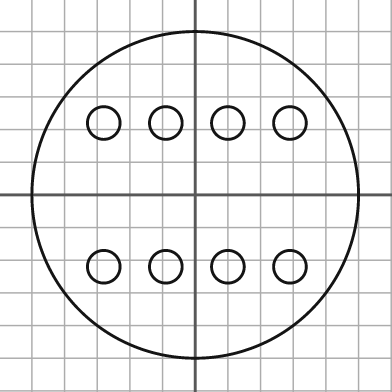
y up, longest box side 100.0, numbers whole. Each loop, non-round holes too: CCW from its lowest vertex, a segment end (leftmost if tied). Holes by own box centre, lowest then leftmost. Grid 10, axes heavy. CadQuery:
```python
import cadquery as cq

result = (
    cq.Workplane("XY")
    .moveTo(0.0, 0.0)
    .circle(50.0)
    .moveTo(-28.0, -22.0)
    .circle(5.0)
    .moveTo(-9.0, -22.0)
    .circle(5.0)
    .moveTo(10.0, -22.0)
    .circle(5.0)
    .moveTo(29.0, -22.0)
    .circle(5.0)
    .moveTo(-28.0, 22.0)
    .circle(5.0)
    .moveTo(-9.0, 22.0)
    .circle(5.0)
    .moveTo(10.0, 22.0)
    .circle(5.0)
    .moveTo(29.0, 22.0)
    .circle(5.0)
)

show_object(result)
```